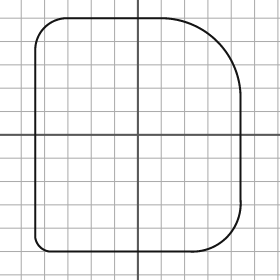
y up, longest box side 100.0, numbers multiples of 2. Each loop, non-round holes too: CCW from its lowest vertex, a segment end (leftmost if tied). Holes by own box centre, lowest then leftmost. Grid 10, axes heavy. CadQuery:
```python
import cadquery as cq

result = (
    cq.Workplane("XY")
    .moveTo(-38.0, -50.0)
    .lineTo(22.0, -50.0)
    .threePointArc((38.0, -44.0), (44.0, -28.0))
    .lineTo(44.0, 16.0)
    .threePointArc((34.0, 40.0), (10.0, 50.0))
    .lineTo(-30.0, 50.0)
    .threePointArc((-40.0, 46.0), (-44.0, 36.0))
    .lineTo(-44.0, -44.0)
    .threePointArc((-42.0, -48.0), (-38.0, -50.0))
    .close()
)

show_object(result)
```